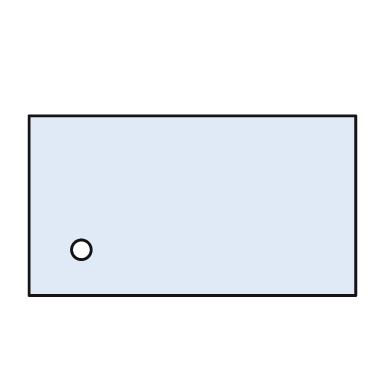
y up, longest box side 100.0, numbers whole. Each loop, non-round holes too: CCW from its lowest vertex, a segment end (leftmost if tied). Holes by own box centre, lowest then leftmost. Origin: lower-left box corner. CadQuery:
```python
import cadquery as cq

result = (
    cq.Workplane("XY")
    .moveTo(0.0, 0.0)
    .lineTo(100.0, 0.0)
    .lineTo(100.0, 55.0)
    .lineTo(0.0, 55.0)
    .close()
    .moveTo(16.0, 14.0)
    .circle(3.0)
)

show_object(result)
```